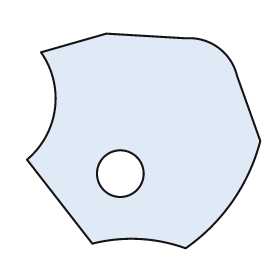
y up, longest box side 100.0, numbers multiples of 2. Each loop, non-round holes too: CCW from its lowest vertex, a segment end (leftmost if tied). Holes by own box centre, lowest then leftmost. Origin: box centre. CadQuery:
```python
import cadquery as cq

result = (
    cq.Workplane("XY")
    .moveTo(18.0, -46.0)
    .threePointArc((38.0, -26.0), (50.0, 0.0))
    .lineTo(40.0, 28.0)
    .threePointArc((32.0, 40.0), (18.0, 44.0))
    .lineTo(-16.0, 46.0)
    .lineTo(-44.0, 38.0)
    .threePointArc((-38.0, 14.0), (-50.0, -8.0))
    .lineTo(-22.0, -44.0)
    .threePointArc((-2.0, -42.0), (18.0, -46.0))
    .close()
    .moveTo(-10.0, -14.0)
    .circle(10.0)
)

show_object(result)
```